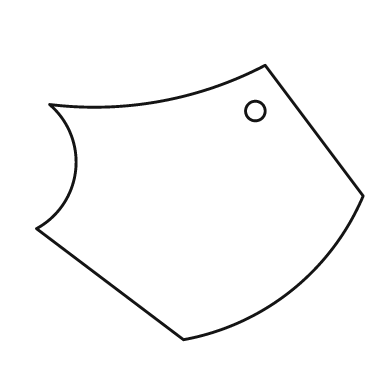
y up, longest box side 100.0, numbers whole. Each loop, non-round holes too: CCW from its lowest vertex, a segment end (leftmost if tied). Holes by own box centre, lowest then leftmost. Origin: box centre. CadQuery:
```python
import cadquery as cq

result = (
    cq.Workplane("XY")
    .moveTo(-5.0, -42.0)
    .threePointArc((28.0, -27.0), (50.0, 2.0))
    .lineTo(20.0, 42.0)
    .threePointArc((-12.0, 31.0), (-46.0, 30.0))
    .threePointArc((-38.0, 10.0), (-50.0, -8.0))
    .close()
    .moveTo(17.0, 28.0)
    .circle(3.0)
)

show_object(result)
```